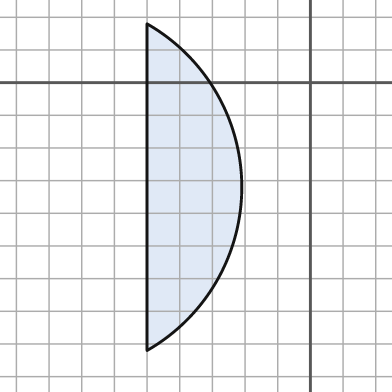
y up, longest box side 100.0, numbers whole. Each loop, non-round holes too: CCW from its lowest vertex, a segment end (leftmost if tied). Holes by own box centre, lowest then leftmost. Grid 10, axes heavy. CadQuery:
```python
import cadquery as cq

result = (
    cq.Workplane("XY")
    .moveTo(-50.0, -82.0)
    .threePointArc((-21.0, -32.0), (-50.0, 18.0))
    .close()
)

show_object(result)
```